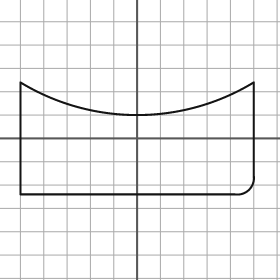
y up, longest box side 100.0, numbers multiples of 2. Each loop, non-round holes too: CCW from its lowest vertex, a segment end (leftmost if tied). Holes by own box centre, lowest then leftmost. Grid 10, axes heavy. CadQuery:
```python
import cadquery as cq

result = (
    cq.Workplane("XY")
    .moveTo(-50.0, -24.0)
    .lineTo(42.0, -24.0)
    .threePointArc((48.0, -22.0), (50.0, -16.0))
    .lineTo(50.0, 24.0)
    .threePointArc((0.0, 10.0), (-50.0, 24.0))
    .close()
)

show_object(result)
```